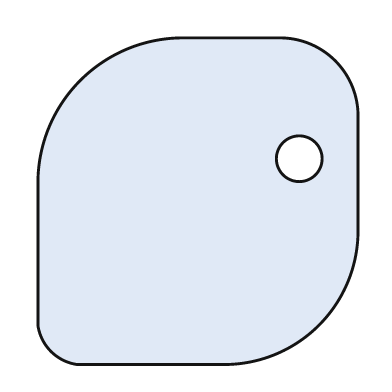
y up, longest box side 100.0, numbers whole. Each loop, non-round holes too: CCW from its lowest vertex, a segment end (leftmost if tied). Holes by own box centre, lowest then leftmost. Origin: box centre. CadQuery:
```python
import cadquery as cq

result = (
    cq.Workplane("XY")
    .moveTo(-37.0, -50.0)
    .lineTo(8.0, -50.0)
    .threePointArc((37.0, -38.0), (49.0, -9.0))
    .lineTo(49.0, 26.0)
    .threePointArc((42.0, 43.0), (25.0, 50.0))
    .lineTo(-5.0, 50.0)
    .threePointArc((-36.0, 37.0), (-49.0, 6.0))
    .lineTo(-49.0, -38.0)
    .threePointArc((-45.0, -46.0), (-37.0, -50.0))
    .close()
    .moveTo(31.0, 13.0)
    .circle(7.0)
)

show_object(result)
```